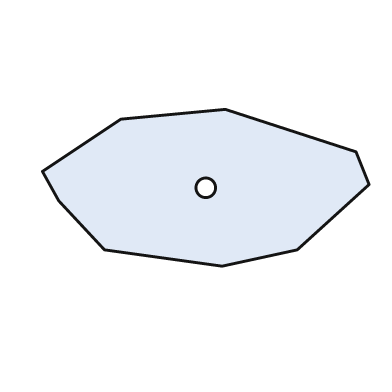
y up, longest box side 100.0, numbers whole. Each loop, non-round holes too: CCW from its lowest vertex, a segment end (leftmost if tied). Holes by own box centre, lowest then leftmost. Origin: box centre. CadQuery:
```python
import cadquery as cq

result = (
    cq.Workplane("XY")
    .moveTo(5.0, -24.0)
    .lineTo(28.0, -19.0)
    .lineTo(50.0, 1.0)
    .lineTo(46.0, 11.0)
    .lineTo(6.0, 24.0)
    .lineTo(-26.0, 21.0)
    .lineTo(-50.0, 5.0)
    .lineTo(-45.0, -4.0)
    .lineTo(-31.0, -19.0)
    .close()
    .moveTo(0.0, 0.0)
    .circle(3.0)
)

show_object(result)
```